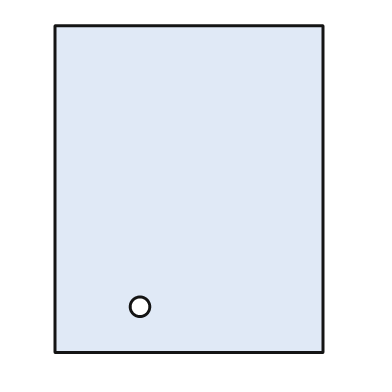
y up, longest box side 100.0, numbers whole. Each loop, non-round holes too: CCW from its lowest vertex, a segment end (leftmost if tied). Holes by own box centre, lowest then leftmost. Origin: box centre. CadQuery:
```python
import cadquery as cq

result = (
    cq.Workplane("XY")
    .moveTo(-41.0, -50.0)
    .lineTo(41.0, -50.0)
    .lineTo(41.0, 50.0)
    .lineTo(-41.0, 50.0)
    .close()
    .moveTo(-15.0, -36.0)
    .circle(3.0)
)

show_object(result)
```